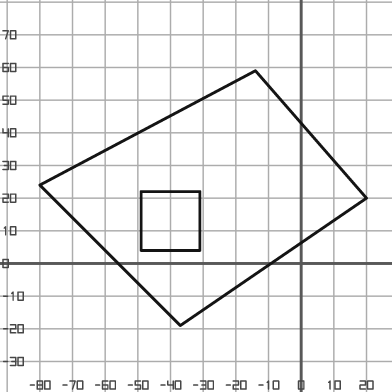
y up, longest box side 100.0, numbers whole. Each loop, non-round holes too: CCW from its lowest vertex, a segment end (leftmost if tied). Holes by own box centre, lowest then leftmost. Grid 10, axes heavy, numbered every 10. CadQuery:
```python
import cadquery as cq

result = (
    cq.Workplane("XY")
    .moveTo(-37.0, -19.0)
    .lineTo(20.0, 20.0)
    .lineTo(-14.0, 59.0)
    .lineTo(-80.0, 24.0)
    .close()
    .moveTo(-49.0, 4.0)
    .lineTo(-31.0, 4.0)
    .lineTo(-31.0, 22.0)
    .lineTo(-49.0, 22.0)
    .close()
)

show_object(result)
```